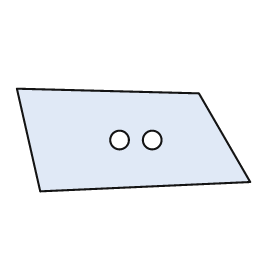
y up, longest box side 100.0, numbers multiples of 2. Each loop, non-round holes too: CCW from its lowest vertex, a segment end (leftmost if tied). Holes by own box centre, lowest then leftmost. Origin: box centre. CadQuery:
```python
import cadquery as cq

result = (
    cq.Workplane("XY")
    .moveTo(-40.0, -22.0)
    .lineTo(50.0, -18.0)
    .lineTo(28.0, 20.0)
    .lineTo(-50.0, 22.0)
    .close()
    .moveTo(-6.0, 0.0)
    .circle(4.0)
    .moveTo(8.0, 0.0)
    .circle(4.0)
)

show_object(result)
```